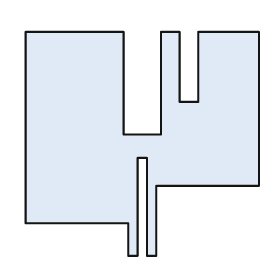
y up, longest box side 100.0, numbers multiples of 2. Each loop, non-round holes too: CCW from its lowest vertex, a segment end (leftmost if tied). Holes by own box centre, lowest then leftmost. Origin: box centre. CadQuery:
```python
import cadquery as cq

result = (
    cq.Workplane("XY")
    .moveTo(-6.0, -48.0)
    .lineTo(-2.0, -48.0)
    .lineTo(-2.0, -6.0)
    .lineTo(2.0, -6.0)
    .lineTo(2.0, -48.0)
    .lineTo(6.0, -48.0)
    .lineTo(6.0, -18.0)
    .lineTo(50.0, -18.0)
    .lineTo(50.0, 48.0)
    .lineTo(24.0, 48.0)
    .lineTo(24.0, 18.0)
    .lineTo(16.0, 18.0)
    .lineTo(16.0, 48.0)
    .lineTo(8.0, 48.0)
    .lineTo(8.0, 4.0)
    .lineTo(-8.0, 4.0)
    .lineTo(-8.0, 48.0)
    .lineTo(-50.0, 48.0)
    .lineTo(-50.0, -34.0)
    .lineTo(-6.0, -34.0)
    .close()
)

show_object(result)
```